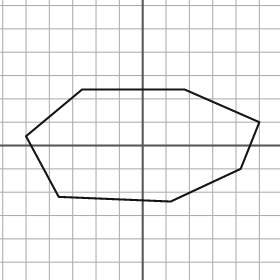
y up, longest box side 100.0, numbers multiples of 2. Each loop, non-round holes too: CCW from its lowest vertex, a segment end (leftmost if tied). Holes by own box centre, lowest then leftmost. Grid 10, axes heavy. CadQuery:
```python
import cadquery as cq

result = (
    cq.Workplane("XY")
    .moveTo(12.0, -24.0)
    .lineTo(42.0, -10.0)
    .lineTo(50.0, 10.0)
    .lineTo(18.0, 24.0)
    .lineTo(-26.0, 24.0)
    .lineTo(-50.0, 4.0)
    .lineTo(-36.0, -22.0)
    .close()
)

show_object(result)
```